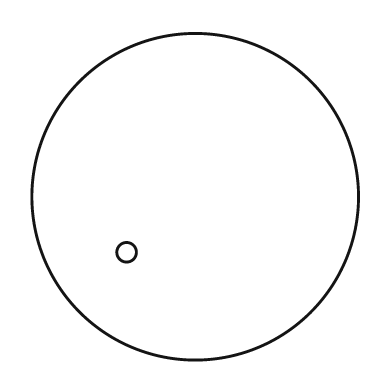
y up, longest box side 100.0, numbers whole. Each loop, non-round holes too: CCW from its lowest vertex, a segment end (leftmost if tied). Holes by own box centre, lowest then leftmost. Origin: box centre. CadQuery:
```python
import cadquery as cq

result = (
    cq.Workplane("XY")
    .moveTo(0.0, 0.0)
    .circle(50.0)
    .moveTo(-21.0, -17.0)
    .circle(3.0)
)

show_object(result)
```